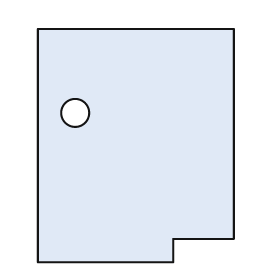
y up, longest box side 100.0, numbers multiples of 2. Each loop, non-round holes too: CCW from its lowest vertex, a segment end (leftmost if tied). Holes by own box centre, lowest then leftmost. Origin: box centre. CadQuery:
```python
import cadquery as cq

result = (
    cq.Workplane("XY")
    .moveTo(-42.0, -50.0)
    .lineTo(16.0, -50.0)
    .lineTo(16.0, -40.0)
    .lineTo(42.0, -40.0)
    .lineTo(42.0, 50.0)
    .lineTo(-42.0, 50.0)
    .close()
    .moveTo(-26.0, 14.0)
    .circle(6.0)
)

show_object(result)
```